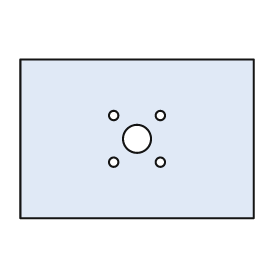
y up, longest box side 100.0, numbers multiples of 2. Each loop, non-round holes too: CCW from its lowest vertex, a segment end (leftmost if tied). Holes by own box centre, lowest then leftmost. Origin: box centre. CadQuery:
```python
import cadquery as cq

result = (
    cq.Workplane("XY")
    .moveTo(-50.0, -34.0)
    .lineTo(50.0, -34.0)
    .lineTo(50.0, 34.0)
    .lineTo(-50.0, 34.0)
    .close()
    .moveTo(-10.0, -10.0)
    .circle(2.0)
    .moveTo(10.0, -10.0)
    .circle(2.0)
    .moveTo(0.0, 0.0)
    .circle(6.0)
    .moveTo(-10.0, 10.0)
    .circle(2.0)
    .moveTo(10.0, 10.0)
    .circle(2.0)
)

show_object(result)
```